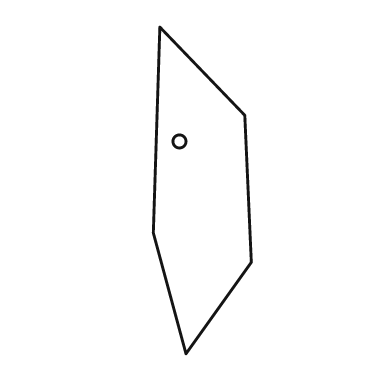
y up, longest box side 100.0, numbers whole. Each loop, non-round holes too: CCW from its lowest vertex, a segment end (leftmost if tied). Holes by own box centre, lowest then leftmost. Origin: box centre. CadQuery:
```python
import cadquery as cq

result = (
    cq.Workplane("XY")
    .moveTo(-5.0, -50.0)
    .lineTo(15.0, -22.0)
    .lineTo(13.0, 23.0)
    .lineTo(-13.0, 50.0)
    .lineTo(-15.0, -13.0)
    .close()
    .moveTo(-7.0, 15.0)
    .circle(2.0)
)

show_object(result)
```